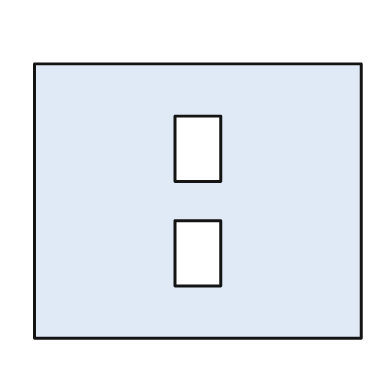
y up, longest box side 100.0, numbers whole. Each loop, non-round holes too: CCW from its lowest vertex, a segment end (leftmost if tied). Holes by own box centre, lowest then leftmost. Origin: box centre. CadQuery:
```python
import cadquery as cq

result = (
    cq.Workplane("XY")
    .moveTo(-50.0, -42.0)
    .lineTo(50.0, -42.0)
    .lineTo(50.0, 42.0)
    .lineTo(-50.0, 42.0)
    .close()
    .moveTo(-7.0, -26.0)
    .lineTo(7.0, -26.0)
    .lineTo(7.0, -6.0)
    .lineTo(-7.0, -6.0)
    .close()
    .moveTo(-7.0, 6.0)
    .lineTo(7.0, 6.0)
    .lineTo(7.0, 26.0)
    .lineTo(-7.0, 26.0)
    .close()
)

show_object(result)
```